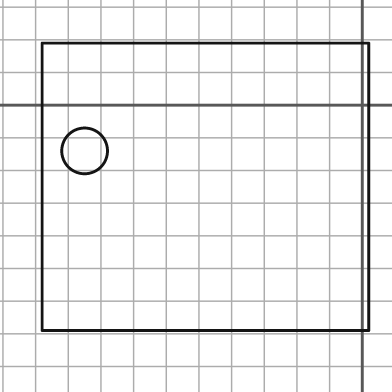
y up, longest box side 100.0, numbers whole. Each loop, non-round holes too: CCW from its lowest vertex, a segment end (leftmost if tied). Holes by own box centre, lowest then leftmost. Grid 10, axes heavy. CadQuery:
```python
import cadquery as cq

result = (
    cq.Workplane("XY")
    .moveTo(-98.0, -69.0)
    .lineTo(2.0, -69.0)
    .lineTo(2.0, 19.0)
    .lineTo(-98.0, 19.0)
    .close()
    .moveTo(-85.0, -14.0)
    .circle(7.0)
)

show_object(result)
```